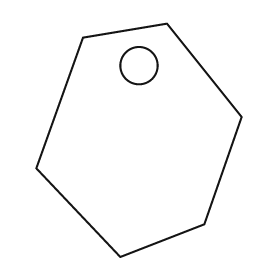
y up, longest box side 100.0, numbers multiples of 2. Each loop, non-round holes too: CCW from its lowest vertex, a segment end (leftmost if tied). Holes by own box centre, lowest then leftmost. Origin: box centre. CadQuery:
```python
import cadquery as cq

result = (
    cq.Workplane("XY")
    .moveTo(-8.0, -50.0)
    .lineTo(28.0, -36.0)
    .lineTo(44.0, 10.0)
    .lineTo(12.0, 50.0)
    .lineTo(-24.0, 44.0)
    .lineTo(-44.0, -12.0)
    .close()
    .moveTo(0.0, 32.0)
    .circle(8.0)
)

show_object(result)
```